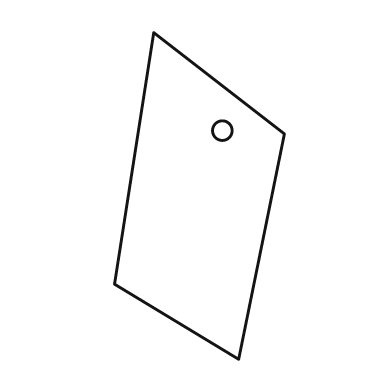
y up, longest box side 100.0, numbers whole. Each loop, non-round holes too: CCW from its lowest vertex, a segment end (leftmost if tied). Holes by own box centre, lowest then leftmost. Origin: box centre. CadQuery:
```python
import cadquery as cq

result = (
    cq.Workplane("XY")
    .moveTo(12.0, -50.0)
    .lineTo(26.0, 19.0)
    .lineTo(-14.0, 50.0)
    .lineTo(-26.0, -27.0)
    .close()
    .moveTo(7.0, 20.0)
    .circle(3.0)
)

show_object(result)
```